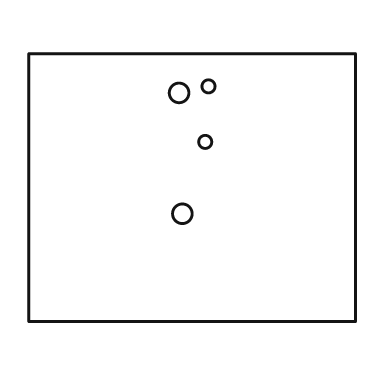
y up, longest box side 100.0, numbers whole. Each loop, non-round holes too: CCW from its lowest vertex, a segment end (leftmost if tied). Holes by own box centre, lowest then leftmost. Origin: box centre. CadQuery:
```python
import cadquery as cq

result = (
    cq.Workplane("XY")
    .moveTo(-50.0, -41.0)
    .lineTo(50.0, -41.0)
    .lineTo(50.0, 41.0)
    .lineTo(-50.0, 41.0)
    .close()
    .moveTo(-3.0, -8.0)
    .circle(3.0)
    .moveTo(4.0, 14.0)
    .circle(2.0)
    .moveTo(-4.0, 29.0)
    .circle(3.0)
    .moveTo(5.0, 31.0)
    .circle(2.0)
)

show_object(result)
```